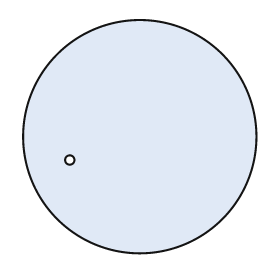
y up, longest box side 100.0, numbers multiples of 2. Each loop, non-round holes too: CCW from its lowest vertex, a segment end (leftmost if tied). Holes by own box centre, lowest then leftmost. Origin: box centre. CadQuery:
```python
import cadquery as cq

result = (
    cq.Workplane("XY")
    .moveTo(0.0, 0.0)
    .circle(50.0)
    .moveTo(-30.0, -10.0)
    .circle(2.0)
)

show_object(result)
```